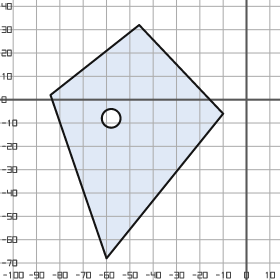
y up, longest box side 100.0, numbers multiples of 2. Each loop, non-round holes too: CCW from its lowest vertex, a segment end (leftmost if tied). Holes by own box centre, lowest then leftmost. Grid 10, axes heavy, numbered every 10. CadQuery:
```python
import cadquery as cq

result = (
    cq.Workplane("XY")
    .moveTo(-60.0, -68.0)
    .lineTo(-10.0, -6.0)
    .lineTo(-46.0, 32.0)
    .lineTo(-84.0, 2.0)
    .close()
    .moveTo(-58.0, -8.0)
    .circle(4.0)
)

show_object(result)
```